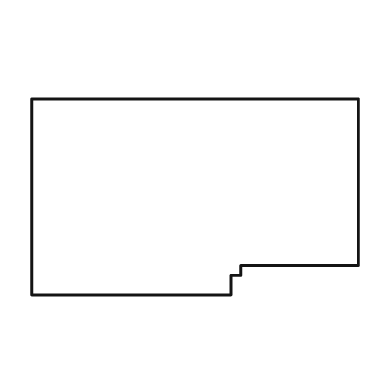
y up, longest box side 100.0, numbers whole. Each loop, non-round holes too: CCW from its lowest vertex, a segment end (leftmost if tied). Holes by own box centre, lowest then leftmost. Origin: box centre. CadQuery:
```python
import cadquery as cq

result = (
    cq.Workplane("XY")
    .moveTo(-50.0, -30.0)
    .lineTo(11.0, -30.0)
    .lineTo(11.0, -24.0)
    .lineTo(14.0, -24.0)
    .lineTo(14.0, -21.0)
    .lineTo(50.0, -21.0)
    .lineTo(50.0, 30.0)
    .lineTo(-50.0, 30.0)
    .close()
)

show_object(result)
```